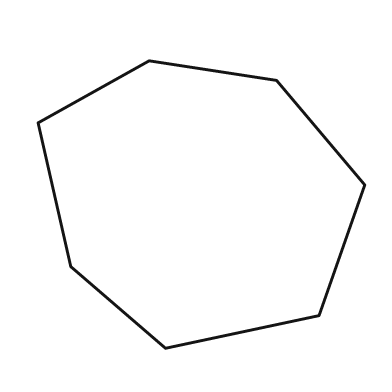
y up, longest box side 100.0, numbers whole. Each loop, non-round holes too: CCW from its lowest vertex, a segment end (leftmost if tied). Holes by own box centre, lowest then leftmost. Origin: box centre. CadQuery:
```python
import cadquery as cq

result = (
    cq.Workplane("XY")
    .moveTo(-11.0, -44.0)
    .lineTo(36.0, -34.0)
    .lineTo(50.0, 6.0)
    .lineTo(23.0, 38.0)
    .lineTo(-16.0, 44.0)
    .lineTo(-50.0, 25.0)
    .lineTo(-40.0, -19.0)
    .close()
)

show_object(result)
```